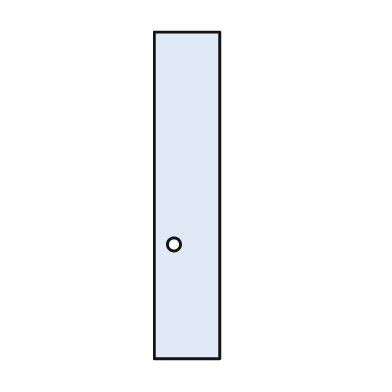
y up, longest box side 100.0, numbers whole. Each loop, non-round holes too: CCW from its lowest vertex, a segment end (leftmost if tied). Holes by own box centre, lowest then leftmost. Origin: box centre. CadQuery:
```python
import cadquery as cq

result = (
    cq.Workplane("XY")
    .moveTo(-10.0, -50.0)
    .lineTo(10.0, -50.0)
    .lineTo(10.0, 50.0)
    .lineTo(-10.0, 50.0)
    .close()
    .moveTo(-4.0, -15.0)
    .circle(2.0)
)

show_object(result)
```